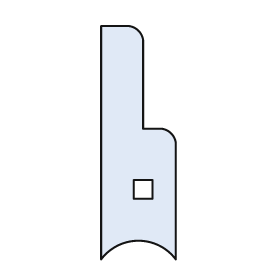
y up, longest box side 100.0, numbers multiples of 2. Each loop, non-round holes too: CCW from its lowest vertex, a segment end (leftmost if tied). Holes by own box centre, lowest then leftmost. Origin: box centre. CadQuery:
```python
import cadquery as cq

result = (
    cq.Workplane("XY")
    .moveTo(-16.0, -50.0)
    .threePointArc((0.0, -42.0), (16.0, -50.0))
    .lineTo(16.0, 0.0)
    .threePointArc((14.0, 4.0), (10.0, 6.0))
    .lineTo(2.0, 6.0)
    .lineTo(2.0, 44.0)
    .threePointArc((0.0, 48.0), (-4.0, 50.0))
    .lineTo(-16.0, 50.0)
    .close()
    .moveTo(-2.0, -24.0)
    .lineTo(6.0, -24.0)
    .lineTo(6.0, -16.0)
    .lineTo(-2.0, -16.0)
    .close()
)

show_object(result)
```